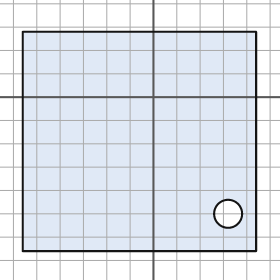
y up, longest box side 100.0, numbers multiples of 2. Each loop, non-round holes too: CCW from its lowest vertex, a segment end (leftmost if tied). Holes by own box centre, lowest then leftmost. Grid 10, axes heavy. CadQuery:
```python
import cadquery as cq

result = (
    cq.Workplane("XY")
    .moveTo(-56.0, -66.0)
    .lineTo(44.0, -66.0)
    .lineTo(44.0, 28.0)
    .lineTo(-56.0, 28.0)
    .close()
    .moveTo(32.0, -50.0)
    .circle(6.0)
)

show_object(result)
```